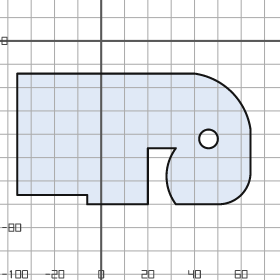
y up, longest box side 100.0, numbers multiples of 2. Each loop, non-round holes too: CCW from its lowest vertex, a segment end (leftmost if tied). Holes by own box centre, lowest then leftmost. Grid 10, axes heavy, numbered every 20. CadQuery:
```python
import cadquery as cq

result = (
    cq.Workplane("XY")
    .moveTo(-6.0, -70.0)
    .lineTo(20.0, -70.0)
    .lineTo(20.0, -46.0)
    .lineTo(32.0, -46.0)
    .threePointArc((28.0, -58.0), (32.0, -70.0))
    .lineTo(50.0, -70.0)
    .threePointArc((60.0, -66.0), (64.0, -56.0))
    .lineTo(64.0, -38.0)
    .threePointArc((56.0, -22.0), (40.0, -14.0))
    .lineTo(-36.0, -14.0)
    .lineTo(-36.0, -66.0)
    .lineTo(-6.0, -66.0)
    .close()
    .moveTo(46.0, -42.0)
    .circle(4.0)
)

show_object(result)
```